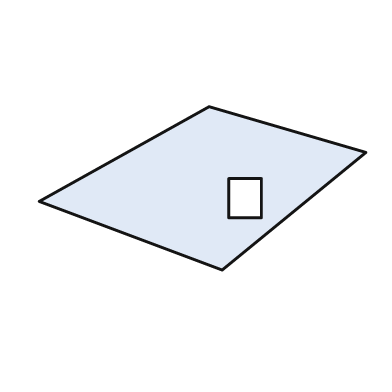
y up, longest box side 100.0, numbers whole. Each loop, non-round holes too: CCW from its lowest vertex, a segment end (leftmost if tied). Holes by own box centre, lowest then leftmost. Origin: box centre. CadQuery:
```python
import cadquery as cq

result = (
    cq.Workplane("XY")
    .moveTo(6.0, -25.0)
    .lineTo(50.0, 11.0)
    .lineTo(2.0, 25.0)
    .lineTo(-50.0, -4.0)
    .close()
    .moveTo(8.0, -9.0)
    .lineTo(18.0, -9.0)
    .lineTo(18.0, 3.0)
    .lineTo(8.0, 3.0)
    .close()
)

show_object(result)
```